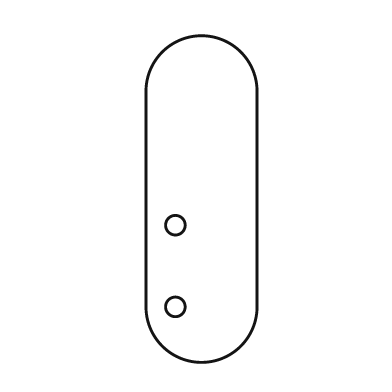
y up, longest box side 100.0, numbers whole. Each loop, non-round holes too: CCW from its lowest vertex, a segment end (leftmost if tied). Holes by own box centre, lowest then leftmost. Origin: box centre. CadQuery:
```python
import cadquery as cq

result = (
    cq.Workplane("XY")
    .moveTo(-17.0, -33.0)
    .threePointArc((0.0, -50.0), (17.0, -33.0))
    .lineTo(17.0, 33.0)
    .threePointArc((0.0, 50.0), (-17.0, 33.0))
    .close()
    .moveTo(-8.0, -33.0)
    .circle(3.0)
    .moveTo(-8.0, -8.0)
    .circle(3.0)
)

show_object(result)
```